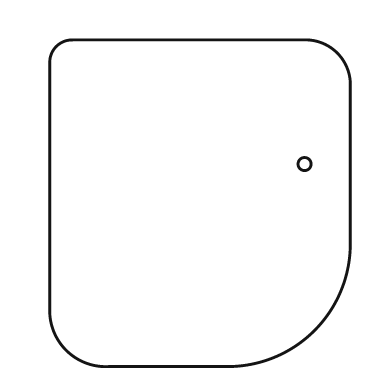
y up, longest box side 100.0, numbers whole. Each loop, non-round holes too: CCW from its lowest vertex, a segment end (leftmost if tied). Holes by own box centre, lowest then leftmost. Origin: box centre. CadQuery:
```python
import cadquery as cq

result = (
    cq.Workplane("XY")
    .moveTo(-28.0, -50.0)
    .lineTo(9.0, -50.0)
    .threePointArc((35.0, -39.0), (46.0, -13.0))
    .lineTo(46.0, 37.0)
    .threePointArc((42.0, 46.0), (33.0, 50.0))
    .lineTo(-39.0, 50.0)
    .threePointArc((-44.0, 48.0), (-46.0, 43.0))
    .lineTo(-46.0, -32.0)
    .threePointArc((-41.0, -45.0), (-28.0, -50.0))
    .close()
    .moveTo(32.0, 12.0)
    .circle(2.0)
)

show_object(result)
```